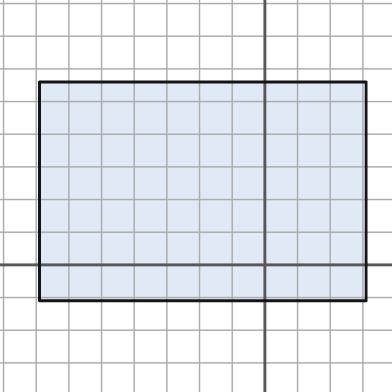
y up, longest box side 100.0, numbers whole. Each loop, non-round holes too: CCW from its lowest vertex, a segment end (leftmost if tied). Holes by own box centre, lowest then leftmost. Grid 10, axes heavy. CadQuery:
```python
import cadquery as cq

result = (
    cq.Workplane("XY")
    .moveTo(-69.0, -11.0)
    .lineTo(31.0, -11.0)
    .lineTo(31.0, 56.0)
    .lineTo(-69.0, 56.0)
    .close()
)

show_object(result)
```